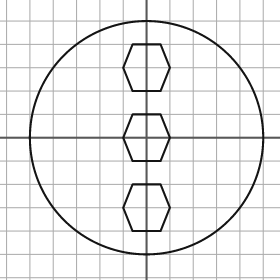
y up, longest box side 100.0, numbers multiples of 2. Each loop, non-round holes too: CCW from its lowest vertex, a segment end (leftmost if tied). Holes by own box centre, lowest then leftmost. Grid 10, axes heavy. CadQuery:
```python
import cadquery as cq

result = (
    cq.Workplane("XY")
    .moveTo(0.0, 0.0)
    .circle(50.0)
    .moveTo(-6.0, -40.0)
    .lineTo(6.0, -40.0)
    .lineTo(10.0, -30.0)
    .lineTo(6.0, -20.0)
    .lineTo(-6.0, -20.0)
    .lineTo(-10.0, -30.0)
    .close()
    .moveTo(-6.0, -10.0)
    .lineTo(6.0, -10.0)
    .lineTo(10.0, 0.0)
    .lineTo(6.0, 10.0)
    .lineTo(-6.0, 10.0)
    .lineTo(-10.0, 0.0)
    .close()
    .moveTo(-6.0, 20.0)
    .lineTo(6.0, 20.0)
    .lineTo(10.0, 30.0)
    .lineTo(6.0, 40.0)
    .lineTo(-6.0, 40.0)
    .lineTo(-10.0, 30.0)
    .close()
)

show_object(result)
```